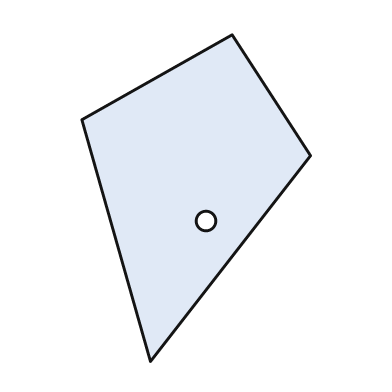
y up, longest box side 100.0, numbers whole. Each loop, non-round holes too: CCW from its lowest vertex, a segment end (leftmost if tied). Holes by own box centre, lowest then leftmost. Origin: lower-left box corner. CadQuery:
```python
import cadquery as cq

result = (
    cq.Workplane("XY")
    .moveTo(21.0, 0.0)
    .lineTo(70.0, 63.0)
    .lineTo(46.0, 100.0)
    .lineTo(0.0, 74.0)
    .close()
    .moveTo(38.0, 43.0)
    .circle(3.0)
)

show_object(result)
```